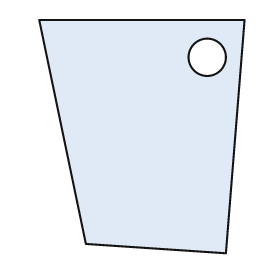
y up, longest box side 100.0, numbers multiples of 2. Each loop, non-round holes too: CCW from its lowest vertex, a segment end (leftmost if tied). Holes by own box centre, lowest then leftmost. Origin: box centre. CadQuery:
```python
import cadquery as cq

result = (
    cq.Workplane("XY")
    .moveTo(36.0, -50.0)
    .lineTo(44.0, 50.0)
    .lineTo(-44.0, 50.0)
    .lineTo(-24.0, -46.0)
    .close()
    .moveTo(28.0, 34.0)
    .circle(8.0)
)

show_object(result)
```